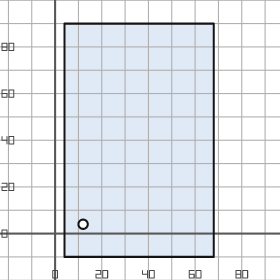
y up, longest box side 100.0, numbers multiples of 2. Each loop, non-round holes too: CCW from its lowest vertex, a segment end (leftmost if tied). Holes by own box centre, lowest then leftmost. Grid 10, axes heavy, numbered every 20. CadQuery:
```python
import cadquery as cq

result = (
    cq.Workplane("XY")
    .moveTo(4.0, -10.0)
    .lineTo(68.0, -10.0)
    .lineTo(68.0, 90.0)
    .lineTo(4.0, 90.0)
    .close()
    .moveTo(12.0, 4.0)
    .circle(2.0)
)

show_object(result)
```